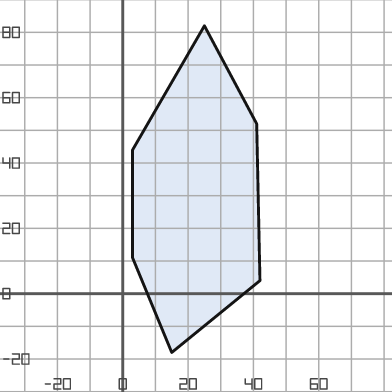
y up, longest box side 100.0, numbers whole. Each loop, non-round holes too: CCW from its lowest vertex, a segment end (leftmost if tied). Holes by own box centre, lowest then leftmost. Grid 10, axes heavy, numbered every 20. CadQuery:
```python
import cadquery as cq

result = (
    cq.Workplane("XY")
    .moveTo(15.0, -18.0)
    .lineTo(42.0, 4.0)
    .lineTo(41.0, 52.0)
    .lineTo(25.0, 82.0)
    .lineTo(3.0, 44.0)
    .lineTo(3.0, 11.0)
    .close()
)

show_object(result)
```